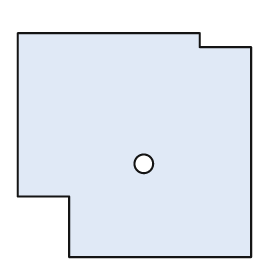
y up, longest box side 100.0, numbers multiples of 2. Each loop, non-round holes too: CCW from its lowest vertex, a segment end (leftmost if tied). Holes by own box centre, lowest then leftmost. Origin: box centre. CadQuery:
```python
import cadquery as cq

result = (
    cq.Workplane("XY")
    .moveTo(-28.0, -48.0)
    .lineTo(50.0, -48.0)
    .lineTo(50.0, 42.0)
    .lineTo(28.0, 42.0)
    .lineTo(28.0, 48.0)
    .lineTo(-50.0, 48.0)
    .lineTo(-50.0, -22.0)
    .lineTo(-28.0, -22.0)
    .close()
    .moveTo(4.0, -8.0)
    .circle(4.0)
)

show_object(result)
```